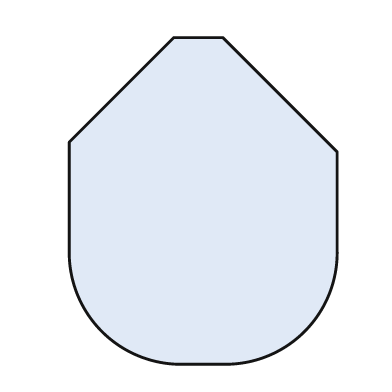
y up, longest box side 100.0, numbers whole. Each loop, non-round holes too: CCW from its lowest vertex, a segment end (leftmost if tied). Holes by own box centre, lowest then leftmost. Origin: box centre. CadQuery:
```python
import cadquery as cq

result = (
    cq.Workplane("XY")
    .moveTo(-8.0, -50.0)
    .lineTo(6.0, -50.0)
    .threePointArc((31.0, -40.0), (41.0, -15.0))
    .lineTo(41.0, 15.0)
    .lineTo(6.0, 50.0)
    .lineTo(-9.0, 50.0)
    .lineTo(-41.0, 18.0)
    .lineTo(-41.0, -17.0)
    .threePointArc((-31.0, -40.0), (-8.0, -50.0))
    .close()
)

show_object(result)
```